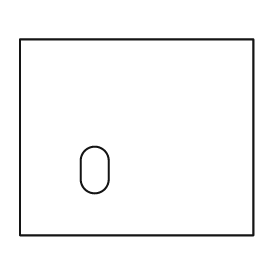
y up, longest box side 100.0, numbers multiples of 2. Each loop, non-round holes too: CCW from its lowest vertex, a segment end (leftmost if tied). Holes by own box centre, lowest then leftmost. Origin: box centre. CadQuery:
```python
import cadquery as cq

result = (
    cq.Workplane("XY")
    .moveTo(-50.0, -42.0)
    .lineTo(50.0, -42.0)
    .lineTo(50.0, 42.0)
    .lineTo(-50.0, 42.0)
    .close()
    .moveTo(-24.0, -18.0)
    .threePointArc((-18.0, -24.0), (-12.0, -18.0))
    .lineTo(-12.0, -10.0)
    .threePointArc((-18.0, -4.0), (-24.0, -10.0))
    .close()
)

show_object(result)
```